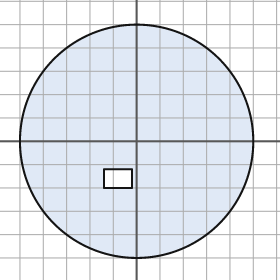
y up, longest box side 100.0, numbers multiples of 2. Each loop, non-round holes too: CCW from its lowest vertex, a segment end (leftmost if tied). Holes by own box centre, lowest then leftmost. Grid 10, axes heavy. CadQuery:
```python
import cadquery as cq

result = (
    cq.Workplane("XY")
    .moveTo(0.0, 0.0)
    .circle(50.0)
    .moveTo(-14.0, -20.0)
    .lineTo(-2.0, -20.0)
    .lineTo(-2.0, -12.0)
    .lineTo(-14.0, -12.0)
    .close()
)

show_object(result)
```